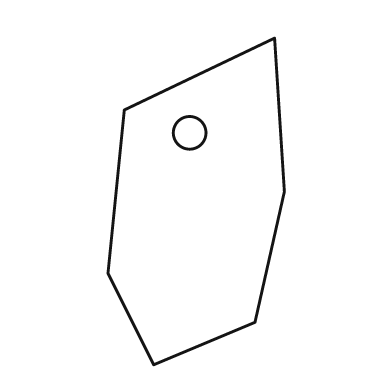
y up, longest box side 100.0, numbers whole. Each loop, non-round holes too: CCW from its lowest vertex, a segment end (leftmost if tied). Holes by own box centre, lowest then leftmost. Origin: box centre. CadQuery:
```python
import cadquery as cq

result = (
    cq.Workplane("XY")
    .moveTo(-13.0, -50.0)
    .lineTo(18.0, -37.0)
    .lineTo(27.0, 3.0)
    .lineTo(24.0, 50.0)
    .lineTo(-22.0, 28.0)
    .lineTo(-27.0, -22.0)
    .close()
    .moveTo(-2.0, 21.0)
    .circle(5.0)
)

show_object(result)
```